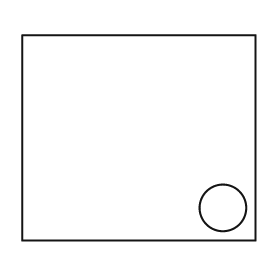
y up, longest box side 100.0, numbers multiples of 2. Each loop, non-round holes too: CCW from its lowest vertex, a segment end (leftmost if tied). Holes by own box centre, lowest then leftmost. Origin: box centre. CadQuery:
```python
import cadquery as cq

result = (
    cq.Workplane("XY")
    .moveTo(-50.0, -44.0)
    .lineTo(50.0, -44.0)
    .lineTo(50.0, 44.0)
    .lineTo(-50.0, 44.0)
    .close()
    .moveTo(36.0, -30.0)
    .circle(10.0)
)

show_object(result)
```